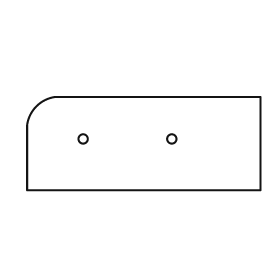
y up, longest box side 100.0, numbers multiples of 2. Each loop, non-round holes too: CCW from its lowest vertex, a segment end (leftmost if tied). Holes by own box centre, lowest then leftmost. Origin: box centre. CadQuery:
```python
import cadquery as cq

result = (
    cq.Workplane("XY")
    .moveTo(-50.0, -20.0)
    .lineTo(50.0, -20.0)
    .lineTo(50.0, 20.0)
    .lineTo(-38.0, 20.0)
    .threePointArc((-46.0, 16.0), (-50.0, 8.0))
    .close()
    .moveTo(-26.0, 2.0)
    .circle(2.0)
    .moveTo(12.0, 2.0)
    .circle(2.0)
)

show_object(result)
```